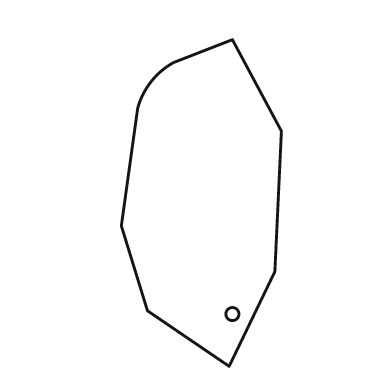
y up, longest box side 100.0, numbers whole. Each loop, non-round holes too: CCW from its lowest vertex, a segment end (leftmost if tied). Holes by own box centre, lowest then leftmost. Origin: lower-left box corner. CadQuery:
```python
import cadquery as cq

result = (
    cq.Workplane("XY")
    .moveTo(33.0, 0.0)
    .lineTo(47.0, 29.0)
    .lineTo(49.0, 72.0)
    .lineTo(34.0, 100.0)
    .lineTo(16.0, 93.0)
    .threePointArc((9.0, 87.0), (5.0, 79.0))
    .lineTo(0.0, 43.0)
    .lineTo(8.0, 17.0)
    .close()
    .moveTo(34.0, 16.0)
    .circle(2.0)
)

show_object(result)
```